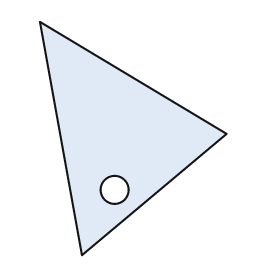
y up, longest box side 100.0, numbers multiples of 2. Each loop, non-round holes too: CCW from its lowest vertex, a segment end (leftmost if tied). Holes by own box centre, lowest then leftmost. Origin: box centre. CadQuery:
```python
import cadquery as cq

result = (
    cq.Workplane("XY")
    .moveTo(-22.0, -50.0)
    .lineTo(40.0, 2.0)
    .lineTo(-40.0, 50.0)
    .close()
    .moveTo(-8.0, -22.0)
    .circle(6.0)
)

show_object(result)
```